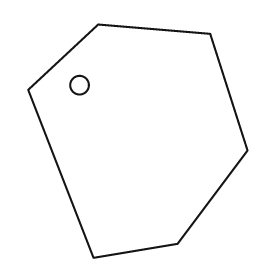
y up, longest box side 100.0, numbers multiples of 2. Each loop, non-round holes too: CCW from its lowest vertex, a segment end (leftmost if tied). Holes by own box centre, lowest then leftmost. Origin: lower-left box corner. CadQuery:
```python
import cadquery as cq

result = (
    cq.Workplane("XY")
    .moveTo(28.0, 0.0)
    .lineTo(64.0, 6.0)
    .lineTo(94.0, 46.0)
    .lineTo(78.0, 96.0)
    .lineTo(30.0, 100.0)
    .lineTo(0.0, 72.0)
    .close()
    .moveTo(22.0, 74.0)
    .circle(4.0)
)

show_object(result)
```